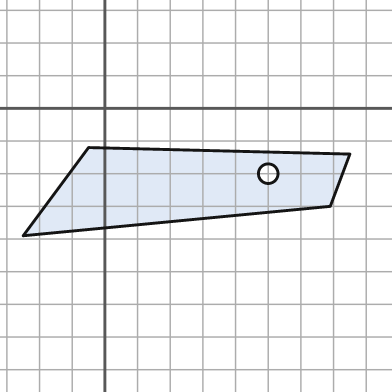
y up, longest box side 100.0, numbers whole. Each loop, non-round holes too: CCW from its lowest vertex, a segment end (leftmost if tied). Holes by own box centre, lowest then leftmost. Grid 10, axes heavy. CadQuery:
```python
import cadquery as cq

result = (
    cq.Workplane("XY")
    .moveTo(-25.0, -39.0)
    .lineTo(69.0, -30.0)
    .lineTo(75.0, -14.0)
    .lineTo(-5.0, -12.0)
    .close()
    .moveTo(50.0, -20.0)
    .circle(3.0)
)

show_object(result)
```